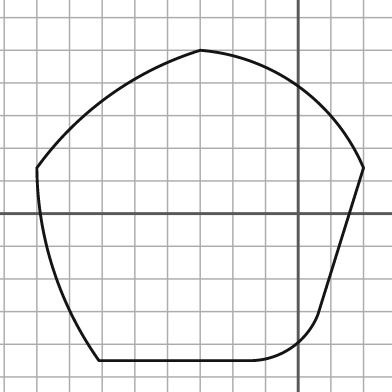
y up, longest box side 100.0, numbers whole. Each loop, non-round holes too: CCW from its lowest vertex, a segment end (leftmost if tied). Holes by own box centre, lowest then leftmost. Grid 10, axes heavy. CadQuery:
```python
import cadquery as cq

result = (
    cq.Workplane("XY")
    .moveTo(-61.0, -45.0)
    .lineTo(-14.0, -45.0)
    .threePointArc((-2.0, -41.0), (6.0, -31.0))
    .lineTo(20.0, 14.0)
    .threePointArc((0.0, 39.0), (-30.0, 50.0))
    .threePointArc((-58.0, 36.0), (-80.0, 14.0))
    .threePointArc((-75.0, -17.0), (-61.0, -45.0))
    .close()
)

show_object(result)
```